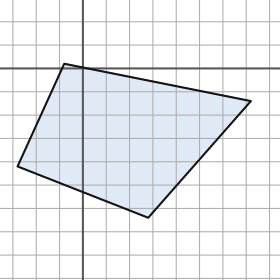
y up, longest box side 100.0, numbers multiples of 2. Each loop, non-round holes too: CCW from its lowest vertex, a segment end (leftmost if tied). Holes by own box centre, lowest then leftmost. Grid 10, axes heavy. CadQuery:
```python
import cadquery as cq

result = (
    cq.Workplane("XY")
    .moveTo(28.0, -64.0)
    .lineTo(72.0, -14.0)
    .lineTo(-8.0, 2.0)
    .lineTo(-28.0, -42.0)
    .close()
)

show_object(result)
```